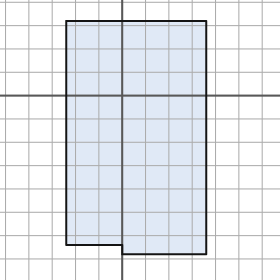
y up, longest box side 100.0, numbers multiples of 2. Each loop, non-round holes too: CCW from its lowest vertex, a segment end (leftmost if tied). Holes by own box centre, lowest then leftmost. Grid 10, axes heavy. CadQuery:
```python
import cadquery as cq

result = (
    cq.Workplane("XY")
    .moveTo(0.0, -68.0)
    .lineTo(36.0, -68.0)
    .lineTo(36.0, 32.0)
    .lineTo(-24.0, 32.0)
    .lineTo(-24.0, -64.0)
    .lineTo(0.0, -64.0)
    .close()
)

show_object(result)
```